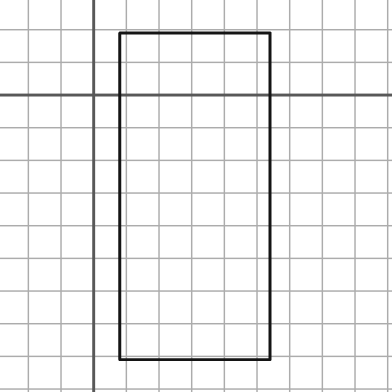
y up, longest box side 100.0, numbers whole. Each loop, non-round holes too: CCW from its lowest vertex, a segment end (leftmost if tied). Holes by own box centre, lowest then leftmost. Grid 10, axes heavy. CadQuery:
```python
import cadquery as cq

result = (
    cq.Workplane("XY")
    .moveTo(8.0, -81.0)
    .lineTo(54.0, -81.0)
    .lineTo(54.0, 19.0)
    .lineTo(8.0, 19.0)
    .close()
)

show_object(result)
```